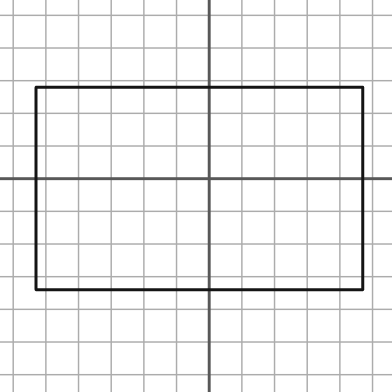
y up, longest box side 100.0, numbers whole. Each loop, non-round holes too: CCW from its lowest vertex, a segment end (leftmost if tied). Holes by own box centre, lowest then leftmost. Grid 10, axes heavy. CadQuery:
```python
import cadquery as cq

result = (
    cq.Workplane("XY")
    .moveTo(-53.0, -34.0)
    .lineTo(47.0, -34.0)
    .lineTo(47.0, 28.0)
    .lineTo(-53.0, 28.0)
    .close()
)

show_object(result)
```